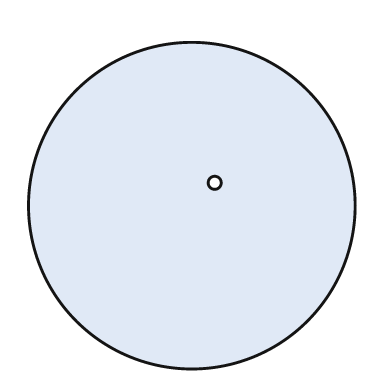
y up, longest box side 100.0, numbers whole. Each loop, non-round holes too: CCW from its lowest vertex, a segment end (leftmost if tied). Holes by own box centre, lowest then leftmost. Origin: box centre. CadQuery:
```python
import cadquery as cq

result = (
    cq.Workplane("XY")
    .moveTo(0.0, 0.0)
    .circle(50.0)
    .moveTo(7.0, 7.0)
    .circle(2.0)
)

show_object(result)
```